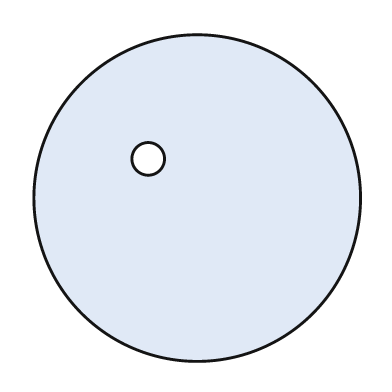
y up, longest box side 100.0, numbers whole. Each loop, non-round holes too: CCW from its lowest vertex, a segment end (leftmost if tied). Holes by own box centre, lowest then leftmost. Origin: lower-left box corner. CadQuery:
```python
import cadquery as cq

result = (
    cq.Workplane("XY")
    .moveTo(50.0, 50.0)
    .circle(50.0)
    .moveTo(35.0, 62.0)
    .circle(5.0)
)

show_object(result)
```